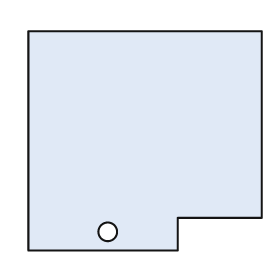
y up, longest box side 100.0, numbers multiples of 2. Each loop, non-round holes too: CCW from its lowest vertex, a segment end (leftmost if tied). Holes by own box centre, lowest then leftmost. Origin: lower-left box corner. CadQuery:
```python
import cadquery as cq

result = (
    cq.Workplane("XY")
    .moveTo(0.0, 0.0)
    .lineTo(64.0, 0.0)
    .lineTo(64.0, 14.0)
    .lineTo(100.0, 14.0)
    .lineTo(100.0, 94.0)
    .lineTo(0.0, 94.0)
    .close()
    .moveTo(34.0, 8.0)
    .circle(4.0)
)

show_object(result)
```